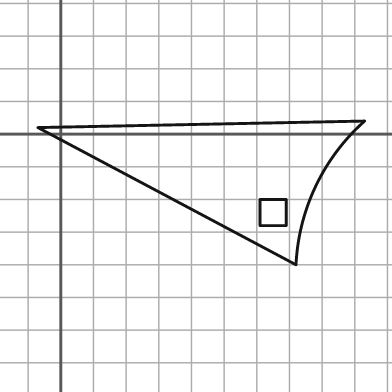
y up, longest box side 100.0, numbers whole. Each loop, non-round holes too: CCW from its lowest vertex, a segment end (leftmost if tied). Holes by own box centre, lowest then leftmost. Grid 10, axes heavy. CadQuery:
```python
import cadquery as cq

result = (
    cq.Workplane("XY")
    .moveTo(72.0, -40.0)
    .threePointArc((78.0, -16.0), (93.0, 4.0))
    .lineTo(-7.0, 2.0)
    .close()
    .moveTo(61.0, -28.0)
    .lineTo(69.0, -28.0)
    .lineTo(69.0, -20.0)
    .lineTo(61.0, -20.0)
    .close()
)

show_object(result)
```